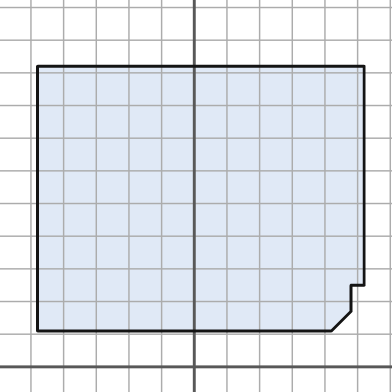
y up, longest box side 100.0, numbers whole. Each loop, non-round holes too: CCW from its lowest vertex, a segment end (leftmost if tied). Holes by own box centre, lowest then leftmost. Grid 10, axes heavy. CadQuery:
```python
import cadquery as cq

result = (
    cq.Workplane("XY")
    .moveTo(-48.0, 11.0)
    .lineTo(42.0, 11.0)
    .lineTo(48.0, 17.0)
    .lineTo(48.0, 25.0)
    .lineTo(52.0, 25.0)
    .lineTo(52.0, 92.0)
    .lineTo(-48.0, 92.0)
    .close()
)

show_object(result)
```